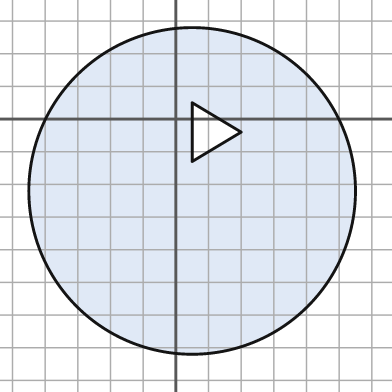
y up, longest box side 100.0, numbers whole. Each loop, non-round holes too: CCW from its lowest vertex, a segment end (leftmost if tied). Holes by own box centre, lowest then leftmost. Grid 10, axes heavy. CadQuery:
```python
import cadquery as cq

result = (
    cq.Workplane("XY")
    .moveTo(5.0, -22.0)
    .circle(50.0)
    .moveTo(5.0, -13.0)
    .lineTo(20.0, -4.0)
    .lineTo(5.0, 5.0)
    .close()
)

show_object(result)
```